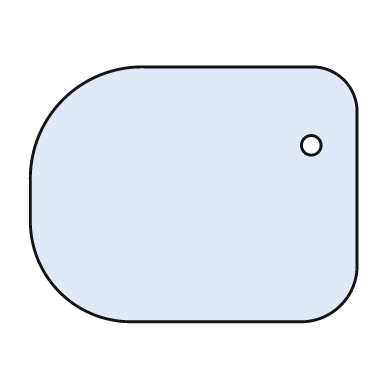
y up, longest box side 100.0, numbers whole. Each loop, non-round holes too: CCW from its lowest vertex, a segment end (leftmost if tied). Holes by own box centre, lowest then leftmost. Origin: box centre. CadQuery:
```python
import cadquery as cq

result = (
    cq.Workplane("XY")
    .moveTo(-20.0, -39.0)
    .lineTo(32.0, -39.0)
    .threePointArc((45.0, -34.0), (50.0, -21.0))
    .lineTo(50.0, 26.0)
    .threePointArc((46.0, 35.0), (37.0, 39.0))
    .lineTo(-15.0, 39.0)
    .threePointArc((-40.0, 29.0), (-50.0, 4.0))
    .lineTo(-50.0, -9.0)
    .threePointArc((-41.0, -30.0), (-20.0, -39.0))
    .close()
    .moveTo(36.0, 15.0)
    .circle(3.0)
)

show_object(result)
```